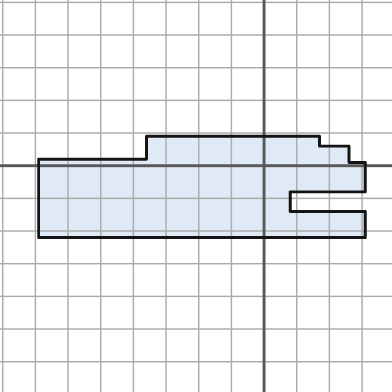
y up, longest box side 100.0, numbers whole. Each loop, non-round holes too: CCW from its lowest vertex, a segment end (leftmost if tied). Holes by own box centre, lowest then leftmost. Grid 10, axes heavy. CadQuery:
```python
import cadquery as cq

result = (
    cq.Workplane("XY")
    .moveTo(-69.0, -22.0)
    .lineTo(31.0, -22.0)
    .lineTo(31.0, -14.0)
    .lineTo(8.0, -14.0)
    .lineTo(8.0, -8.0)
    .lineTo(31.0, -8.0)
    .lineTo(31.0, 1.0)
    .lineTo(26.0, 1.0)
    .lineTo(26.0, 6.0)
    .lineTo(17.0, 6.0)
    .lineTo(17.0, 9.0)
    .lineTo(-36.0, 9.0)
    .lineTo(-36.0, 2.0)
    .lineTo(-69.0, 2.0)
    .close()
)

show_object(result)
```